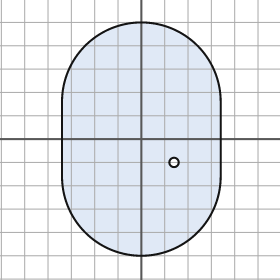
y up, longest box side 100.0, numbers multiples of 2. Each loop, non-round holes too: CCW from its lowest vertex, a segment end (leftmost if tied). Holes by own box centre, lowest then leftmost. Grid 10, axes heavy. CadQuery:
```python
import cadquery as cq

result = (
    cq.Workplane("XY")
    .moveTo(-34.0, -16.0)
    .threePointArc((0.0, -50.0), (34.0, -16.0))
    .lineTo(34.0, 16.0)
    .threePointArc((0.0, 50.0), (-34.0, 16.0))
    .close()
    .moveTo(14.0, -10.0)
    .circle(2.0)
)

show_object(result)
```